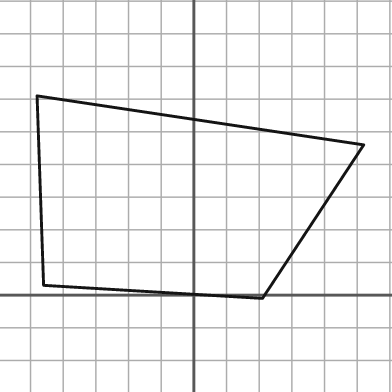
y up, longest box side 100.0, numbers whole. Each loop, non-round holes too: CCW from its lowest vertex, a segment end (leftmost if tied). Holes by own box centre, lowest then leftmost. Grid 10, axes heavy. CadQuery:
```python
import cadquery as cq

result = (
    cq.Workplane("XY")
    .moveTo(21.0, -1.0)
    .lineTo(52.0, 46.0)
    .lineTo(-48.0, 61.0)
    .lineTo(-46.0, 3.0)
    .close()
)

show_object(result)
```